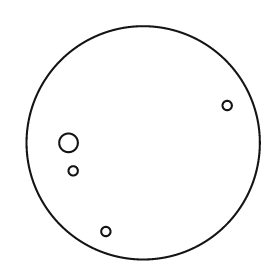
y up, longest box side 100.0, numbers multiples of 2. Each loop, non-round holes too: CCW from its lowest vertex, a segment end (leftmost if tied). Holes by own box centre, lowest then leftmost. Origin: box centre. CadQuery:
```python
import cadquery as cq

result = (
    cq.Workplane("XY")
    .moveTo(0.0, 0.0)
    .circle(50.0)
    .moveTo(-16.0, -38.0)
    .circle(2.0)
    .moveTo(-30.0, -12.0)
    .circle(2.0)
    .moveTo(-32.0, 0.0)
    .circle(4.0)
    .moveTo(36.0, 16.0)
    .circle(2.0)
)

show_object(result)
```